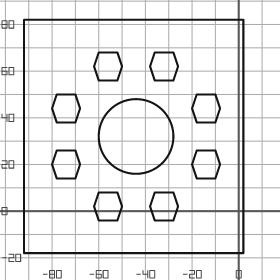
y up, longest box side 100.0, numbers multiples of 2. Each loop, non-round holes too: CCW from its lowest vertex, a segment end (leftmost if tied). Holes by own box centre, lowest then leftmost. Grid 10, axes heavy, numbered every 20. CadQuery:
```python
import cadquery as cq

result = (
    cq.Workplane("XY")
    .moveTo(-92.0, -18.0)
    .lineTo(2.0, -18.0)
    .lineTo(2.0, 82.0)
    .lineTo(-92.0, 82.0)
    .close()
    .moveTo(-60.0, -4.0)
    .lineTo(-52.0, -4.0)
    .lineTo(-50.0, 2.0)
    .lineTo(-52.0, 8.0)
    .lineTo(-60.0, 8.0)
    .lineTo(-62.0, 2.0)
    .close()
    .moveTo(-36.0, -4.0)
    .lineTo(-28.0, -4.0)
    .lineTo(-26.0, 2.0)
    .lineTo(-28.0, 8.0)
    .lineTo(-36.0, 8.0)
    .lineTo(-38.0, 2.0)
    .close()
    .moveTo(-78.0, 14.0)
    .lineTo(-70.0, 14.0)
    .lineTo(-68.0, 20.0)
    .lineTo(-70.0, 26.0)
    .lineTo(-78.0, 26.0)
    .lineTo(-80.0, 20.0)
    .close()
    .moveTo(-18.0, 14.0)
    .lineTo(-10.0, 14.0)
    .lineTo(-8.0, 20.0)
    .lineTo(-10.0, 26.0)
    .lineTo(-18.0, 26.0)
    .lineTo(-20.0, 20.0)
    .close()
    .moveTo(-44.0, 32.0)
    .circle(16.0)
    .moveTo(-78.0, 38.0)
    .lineTo(-70.0, 38.0)
    .lineTo(-68.0, 44.0)
    .lineTo(-70.0, 50.0)
    .lineTo(-78.0, 50.0)
    .lineTo(-80.0, 44.0)
    .close()
    .moveTo(-18.0, 38.0)
    .lineTo(-10.0, 38.0)
    .lineTo(-8.0, 44.0)
    .lineTo(-10.0, 50.0)
    .lineTo(-18.0, 50.0)
    .lineTo(-20.0, 44.0)
    .close()
    .moveTo(-60.0, 56.0)
    .lineTo(-52.0, 56.0)
    .lineTo(-50.0, 62.0)
    .lineTo(-52.0, 68.0)
    .lineTo(-60.0, 68.0)
    .lineTo(-62.0, 62.0)
    .close()
    .moveTo(-36.0, 56.0)
    .lineTo(-28.0, 56.0)
    .lineTo(-26.0, 62.0)
    .lineTo(-28.0, 68.0)
    .lineTo(-36.0, 68.0)
    .lineTo(-38.0, 62.0)
    .close()
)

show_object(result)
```